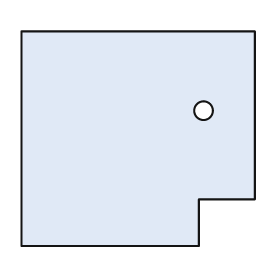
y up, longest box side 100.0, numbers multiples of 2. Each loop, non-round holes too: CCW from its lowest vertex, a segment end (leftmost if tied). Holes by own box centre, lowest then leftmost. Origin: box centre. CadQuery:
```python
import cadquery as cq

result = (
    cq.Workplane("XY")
    .moveTo(-50.0, -46.0)
    .lineTo(26.0, -46.0)
    .lineTo(26.0, -26.0)
    .lineTo(50.0, -26.0)
    .lineTo(50.0, 46.0)
    .lineTo(-50.0, 46.0)
    .close()
    .moveTo(28.0, 12.0)
    .circle(4.0)
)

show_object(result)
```